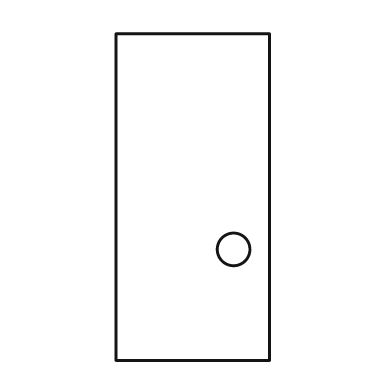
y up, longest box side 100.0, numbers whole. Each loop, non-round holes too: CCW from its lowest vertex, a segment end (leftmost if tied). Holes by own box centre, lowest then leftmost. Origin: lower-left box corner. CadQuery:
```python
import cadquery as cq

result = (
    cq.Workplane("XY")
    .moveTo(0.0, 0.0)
    .lineTo(47.0, 0.0)
    .lineTo(47.0, 100.0)
    .lineTo(0.0, 100.0)
    .close()
    .moveTo(36.0, 34.0)
    .circle(5.0)
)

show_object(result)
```